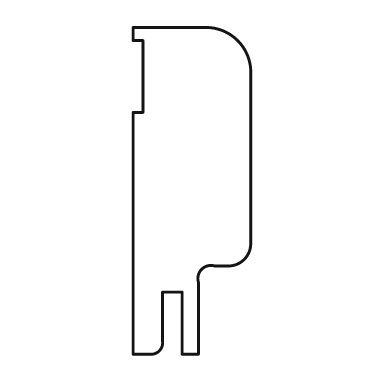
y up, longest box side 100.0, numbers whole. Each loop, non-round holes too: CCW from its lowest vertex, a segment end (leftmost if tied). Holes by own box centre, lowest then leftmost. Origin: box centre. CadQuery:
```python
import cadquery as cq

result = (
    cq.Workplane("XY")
    .moveTo(-18.0, -50.0)
    .lineTo(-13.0, -50.0)
    .threePointArc((-10.0, -49.0), (-9.0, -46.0))
    .lineTo(-9.0, -31.0)
    .lineTo(-3.0, -31.0)
    .lineTo(-3.0, -50.0)
    .lineTo(2.0, -50.0)
    .lineTo(2.0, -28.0)
    .threePointArc((3.0, -24.0), (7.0, -23.0))
    .lineTo(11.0, -23.0)
    .threePointArc((16.0, -21.0), (18.0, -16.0))
    .lineTo(18.0, 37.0)
    .threePointArc((14.0, 46.0), (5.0, 50.0))
    .lineTo(-18.0, 50.0)
    .lineTo(-18.0, 46.0)
    .lineTo(-15.0, 46.0)
    .lineTo(-15.0, 24.0)
    .lineTo(-18.0, 24.0)
    .close()
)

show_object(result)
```